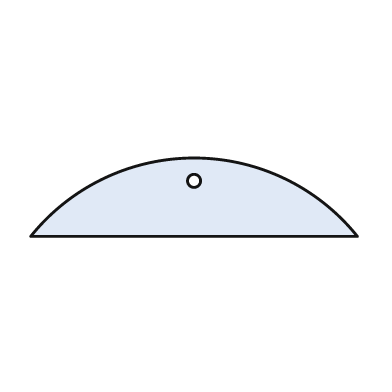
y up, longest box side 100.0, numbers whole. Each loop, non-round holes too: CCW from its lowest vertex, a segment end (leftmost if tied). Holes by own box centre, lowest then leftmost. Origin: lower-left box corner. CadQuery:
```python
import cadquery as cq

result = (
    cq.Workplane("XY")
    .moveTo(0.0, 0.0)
    .lineTo(100.0, 0.0)
    .threePointArc((50.0, 24.0), (0.0, 0.0))
    .close()
    .moveTo(50.0, 17.0)
    .circle(2.0)
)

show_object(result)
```